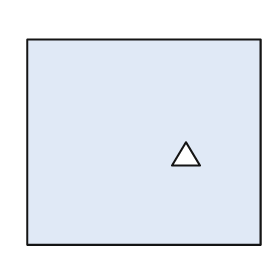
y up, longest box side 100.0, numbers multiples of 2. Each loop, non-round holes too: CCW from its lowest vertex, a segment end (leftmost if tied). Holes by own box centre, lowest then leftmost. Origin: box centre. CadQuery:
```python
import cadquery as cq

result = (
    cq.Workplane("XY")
    .moveTo(-50.0, -44.0)
    .lineTo(50.0, -44.0)
    .lineTo(50.0, 44.0)
    .lineTo(-50.0, 44.0)
    .close()
    .moveTo(12.0, -10.0)
    .lineTo(24.0, -10.0)
    .lineTo(18.0, 0.0)
    .close()
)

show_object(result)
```